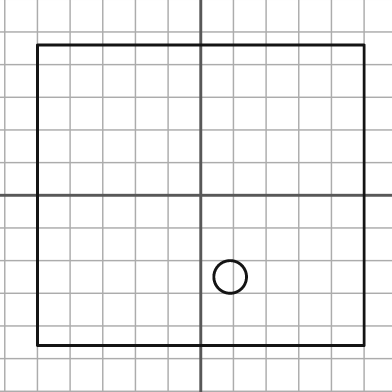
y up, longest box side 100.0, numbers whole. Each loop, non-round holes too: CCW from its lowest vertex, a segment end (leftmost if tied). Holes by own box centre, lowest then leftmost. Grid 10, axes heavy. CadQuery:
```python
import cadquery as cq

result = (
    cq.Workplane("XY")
    .moveTo(-50.0, -46.0)
    .lineTo(50.0, -46.0)
    .lineTo(50.0, 46.0)
    .lineTo(-50.0, 46.0)
    .close()
    .moveTo(9.0, -25.0)
    .circle(5.0)
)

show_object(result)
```